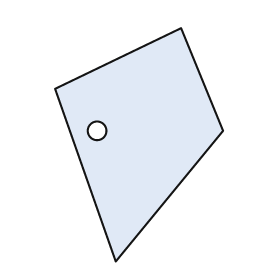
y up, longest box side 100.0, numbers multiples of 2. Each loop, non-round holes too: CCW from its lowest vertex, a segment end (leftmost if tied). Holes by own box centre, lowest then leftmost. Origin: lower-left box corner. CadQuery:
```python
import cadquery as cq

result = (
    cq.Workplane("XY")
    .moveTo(26.0, 0.0)
    .lineTo(72.0, 56.0)
    .lineTo(54.0, 100.0)
    .lineTo(0.0, 74.0)
    .close()
    .moveTo(18.0, 56.0)
    .circle(4.0)
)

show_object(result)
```